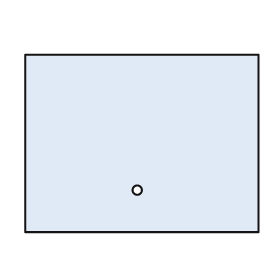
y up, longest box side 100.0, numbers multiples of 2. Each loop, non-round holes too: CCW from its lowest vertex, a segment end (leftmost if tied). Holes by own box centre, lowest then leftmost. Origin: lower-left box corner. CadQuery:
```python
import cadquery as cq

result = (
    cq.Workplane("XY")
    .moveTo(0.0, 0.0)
    .lineTo(100.0, 0.0)
    .lineTo(100.0, 76.0)
    .lineTo(0.0, 76.0)
    .close()
    .moveTo(48.0, 18.0)
    .circle(2.0)
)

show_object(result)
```